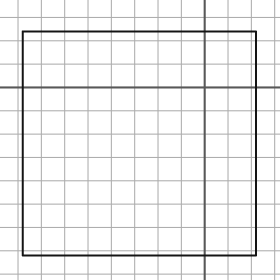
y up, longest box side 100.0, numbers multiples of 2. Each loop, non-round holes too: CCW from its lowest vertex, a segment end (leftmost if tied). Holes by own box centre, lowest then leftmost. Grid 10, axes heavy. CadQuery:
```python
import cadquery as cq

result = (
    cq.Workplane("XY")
    .moveTo(-78.0, -72.0)
    .lineTo(22.0, -72.0)
    .lineTo(22.0, 24.0)
    .lineTo(-78.0, 24.0)
    .close()
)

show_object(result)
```